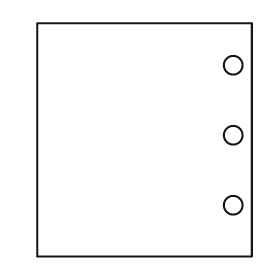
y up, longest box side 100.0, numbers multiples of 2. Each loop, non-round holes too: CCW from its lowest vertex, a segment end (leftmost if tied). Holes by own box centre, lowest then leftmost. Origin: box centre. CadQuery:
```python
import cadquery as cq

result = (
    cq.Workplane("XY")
    .moveTo(-46.0, -50.0)
    .lineTo(46.0, -50.0)
    .lineTo(46.0, 50.0)
    .lineTo(-46.0, 50.0)
    .close()
    .moveTo(38.0, -28.0)
    .circle(4.0)
    .moveTo(38.0, 2.0)
    .circle(4.0)
    .moveTo(38.0, 32.0)
    .circle(4.0)
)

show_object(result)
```